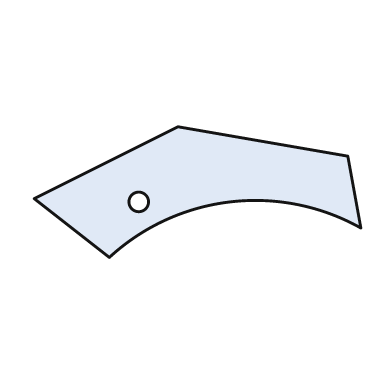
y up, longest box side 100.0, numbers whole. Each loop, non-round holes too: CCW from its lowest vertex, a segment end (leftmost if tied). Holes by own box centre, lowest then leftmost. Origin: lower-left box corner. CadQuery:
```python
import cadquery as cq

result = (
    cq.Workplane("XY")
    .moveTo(23.0, 0.0)
    .threePointArc((60.0, 17.0), (100.0, 9.0))
    .lineTo(96.0, 31.0)
    .lineTo(44.0, 40.0)
    .lineTo(0.0, 18.0)
    .close()
    .moveTo(32.0, 17.0)
    .circle(3.0)
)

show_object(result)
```